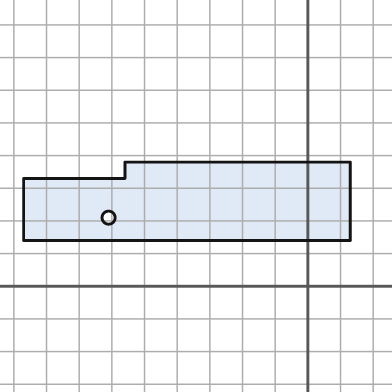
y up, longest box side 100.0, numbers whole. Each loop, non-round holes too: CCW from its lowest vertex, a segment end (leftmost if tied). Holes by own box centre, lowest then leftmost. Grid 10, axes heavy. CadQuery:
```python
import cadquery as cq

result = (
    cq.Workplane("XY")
    .moveTo(-87.0, 14.0)
    .lineTo(13.0, 14.0)
    .lineTo(13.0, 38.0)
    .lineTo(-56.0, 38.0)
    .lineTo(-56.0, 33.0)
    .lineTo(-87.0, 33.0)
    .close()
    .moveTo(-61.0, 21.0)
    .circle(2.0)
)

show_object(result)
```